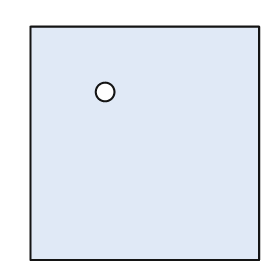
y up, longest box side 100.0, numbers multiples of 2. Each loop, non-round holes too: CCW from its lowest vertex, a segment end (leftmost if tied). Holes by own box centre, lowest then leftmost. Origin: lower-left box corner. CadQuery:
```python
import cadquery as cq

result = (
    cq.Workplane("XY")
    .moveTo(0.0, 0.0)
    .lineTo(98.0, 0.0)
    .lineTo(98.0, 100.0)
    .lineTo(0.0, 100.0)
    .close()
    .moveTo(32.0, 72.0)
    .circle(4.0)
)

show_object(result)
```